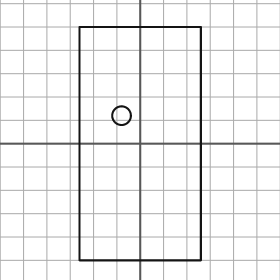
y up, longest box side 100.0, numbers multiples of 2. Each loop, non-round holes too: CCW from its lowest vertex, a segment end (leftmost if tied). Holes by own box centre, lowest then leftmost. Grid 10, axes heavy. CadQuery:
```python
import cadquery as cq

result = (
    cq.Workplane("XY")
    .moveTo(-26.0, -50.0)
    .lineTo(26.0, -50.0)
    .lineTo(26.0, 50.0)
    .lineTo(-26.0, 50.0)
    .close()
    .moveTo(-8.0, 12.0)
    .circle(4.0)
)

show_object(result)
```